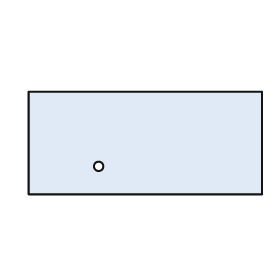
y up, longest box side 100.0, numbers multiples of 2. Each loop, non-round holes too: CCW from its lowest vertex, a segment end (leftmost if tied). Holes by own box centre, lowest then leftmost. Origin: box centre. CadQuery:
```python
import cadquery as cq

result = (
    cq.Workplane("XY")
    .moveTo(-50.0, -22.0)
    .lineTo(50.0, -22.0)
    .lineTo(50.0, 22.0)
    .lineTo(-50.0, 22.0)
    .close()
    .moveTo(-20.0, -10.0)
    .circle(2.0)
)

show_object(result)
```